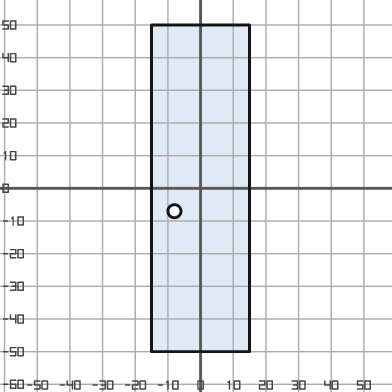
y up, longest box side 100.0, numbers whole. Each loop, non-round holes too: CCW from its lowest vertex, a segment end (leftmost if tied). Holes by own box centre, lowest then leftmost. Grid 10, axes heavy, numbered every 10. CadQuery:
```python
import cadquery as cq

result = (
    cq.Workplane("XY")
    .moveTo(-15.0, -50.0)
    .lineTo(15.0, -50.0)
    .lineTo(15.0, 50.0)
    .lineTo(-15.0, 50.0)
    .close()
    .moveTo(-8.0, -7.0)
    .circle(2.0)
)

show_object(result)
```